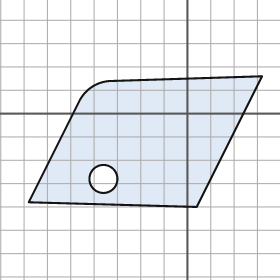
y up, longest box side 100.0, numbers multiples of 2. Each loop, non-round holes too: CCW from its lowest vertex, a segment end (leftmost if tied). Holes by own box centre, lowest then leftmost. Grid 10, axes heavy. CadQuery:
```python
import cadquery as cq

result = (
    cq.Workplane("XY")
    .moveTo(4.0, -40.0)
    .lineTo(32.0, 16.0)
    .lineTo(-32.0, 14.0)
    .threePointArc((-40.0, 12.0), (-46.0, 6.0))
    .lineTo(-68.0, -38.0)
    .close()
    .moveTo(-36.0, -28.0)
    .circle(6.0)
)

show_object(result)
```